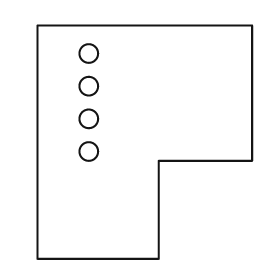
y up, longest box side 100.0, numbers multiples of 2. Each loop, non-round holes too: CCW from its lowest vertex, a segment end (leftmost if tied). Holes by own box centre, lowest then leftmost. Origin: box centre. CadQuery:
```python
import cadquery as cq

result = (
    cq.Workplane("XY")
    .moveTo(-46.0, -50.0)
    .lineTo(6.0, -50.0)
    .lineTo(6.0, -8.0)
    .lineTo(46.0, -8.0)
    .lineTo(46.0, 50.0)
    .lineTo(-46.0, 50.0)
    .close()
    .moveTo(-24.0, -4.0)
    .circle(4.0)
    .moveTo(-24.0, 10.0)
    .circle(4.0)
    .moveTo(-24.0, 24.0)
    .circle(4.0)
    .moveTo(-24.0, 38.0)
    .circle(4.0)
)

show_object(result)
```